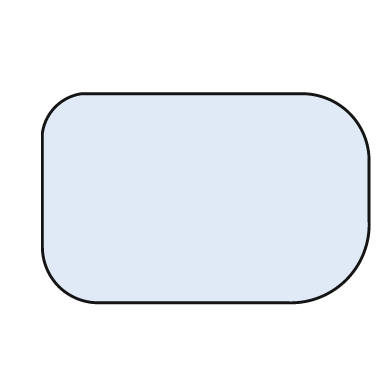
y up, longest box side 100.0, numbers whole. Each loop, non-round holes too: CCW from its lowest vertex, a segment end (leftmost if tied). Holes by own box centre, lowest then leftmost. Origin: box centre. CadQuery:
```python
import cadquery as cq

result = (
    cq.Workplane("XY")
    .moveTo(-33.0, -32.0)
    .lineTo(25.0, -32.0)
    .threePointArc((43.0, -25.0), (50.0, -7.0))
    .lineTo(50.0, 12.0)
    .threePointArc((44.0, 26.0), (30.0, 32.0))
    .lineTo(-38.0, 32.0)
    .threePointArc((-46.0, 28.0), (-50.0, 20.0))
    .lineTo(-50.0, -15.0)
    .threePointArc((-45.0, -27.0), (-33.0, -32.0))
    .close()
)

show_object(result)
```